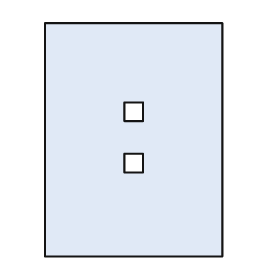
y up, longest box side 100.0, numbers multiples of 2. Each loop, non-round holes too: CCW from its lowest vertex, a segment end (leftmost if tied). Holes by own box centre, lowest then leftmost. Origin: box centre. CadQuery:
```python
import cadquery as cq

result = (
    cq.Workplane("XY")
    .moveTo(-38.0, -50.0)
    .lineTo(38.0, -50.0)
    .lineTo(38.0, 50.0)
    .lineTo(-38.0, 50.0)
    .close()
    .moveTo(-4.0, -14.0)
    .lineTo(4.0, -14.0)
    .lineTo(4.0, -6.0)
    .lineTo(-4.0, -6.0)
    .close()
    .moveTo(-4.0, 8.0)
    .lineTo(4.0, 8.0)
    .lineTo(4.0, 16.0)
    .lineTo(-4.0, 16.0)
    .close()
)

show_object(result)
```